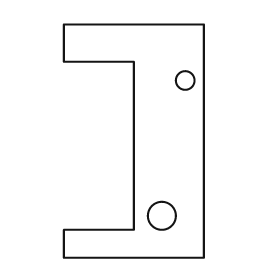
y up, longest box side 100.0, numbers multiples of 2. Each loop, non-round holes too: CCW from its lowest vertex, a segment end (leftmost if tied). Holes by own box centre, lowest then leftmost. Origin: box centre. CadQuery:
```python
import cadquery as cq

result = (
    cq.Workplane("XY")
    .moveTo(-30.0, -50.0)
    .lineTo(30.0, -50.0)
    .lineTo(30.0, 50.0)
    .lineTo(-30.0, 50.0)
    .lineTo(-30.0, 34.0)
    .lineTo(0.0, 34.0)
    .lineTo(0.0, -38.0)
    .lineTo(-30.0, -38.0)
    .close()
    .moveTo(12.0, -32.0)
    .circle(6.0)
    .moveTo(22.0, 26.0)
    .circle(4.0)
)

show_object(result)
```